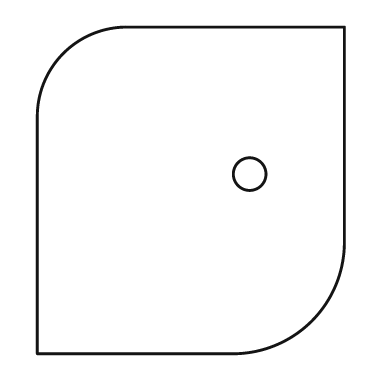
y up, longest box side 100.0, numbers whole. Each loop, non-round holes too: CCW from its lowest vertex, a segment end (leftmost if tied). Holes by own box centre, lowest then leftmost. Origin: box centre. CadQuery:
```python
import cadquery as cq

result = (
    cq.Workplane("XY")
    .moveTo(-47.0, -50.0)
    .lineTo(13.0, -50.0)
    .threePointArc((37.0, -40.0), (47.0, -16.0))
    .lineTo(47.0, 50.0)
    .lineTo(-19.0, 50.0)
    .threePointArc((-39.0, 42.0), (-47.0, 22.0))
    .close()
    .moveTo(18.0, 5.0)
    .circle(5.0)
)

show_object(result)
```